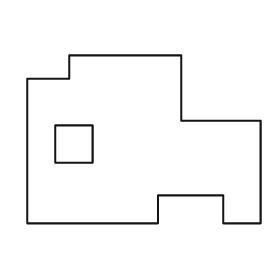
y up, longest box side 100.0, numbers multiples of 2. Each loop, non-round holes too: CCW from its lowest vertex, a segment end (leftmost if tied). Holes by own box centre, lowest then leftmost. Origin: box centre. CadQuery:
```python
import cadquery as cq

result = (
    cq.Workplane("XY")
    .moveTo(-50.0, -36.0)
    .lineTo(6.0, -36.0)
    .lineTo(6.0, -24.0)
    .lineTo(34.0, -24.0)
    .lineTo(34.0, -36.0)
    .lineTo(50.0, -36.0)
    .lineTo(50.0, 8.0)
    .lineTo(16.0, 8.0)
    .lineTo(16.0, 36.0)
    .lineTo(-32.0, 36.0)
    .lineTo(-32.0, 26.0)
    .lineTo(-50.0, 26.0)
    .close()
    .moveTo(-38.0, -10.0)
    .lineTo(-22.0, -10.0)
    .lineTo(-22.0, 6.0)
    .lineTo(-38.0, 6.0)
    .close()
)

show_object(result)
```